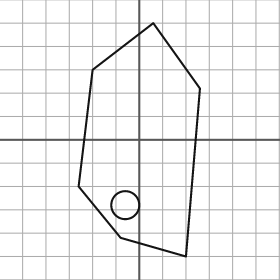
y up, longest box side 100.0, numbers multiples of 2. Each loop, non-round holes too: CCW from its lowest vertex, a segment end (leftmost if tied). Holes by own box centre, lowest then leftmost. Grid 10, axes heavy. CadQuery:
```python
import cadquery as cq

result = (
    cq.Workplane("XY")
    .moveTo(20.0, -50.0)
    .lineTo(26.0, 22.0)
    .lineTo(6.0, 50.0)
    .lineTo(-20.0, 30.0)
    .lineTo(-26.0, -20.0)
    .lineTo(-8.0, -42.0)
    .close()
    .moveTo(-6.0, -28.0)
    .circle(6.0)
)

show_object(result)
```